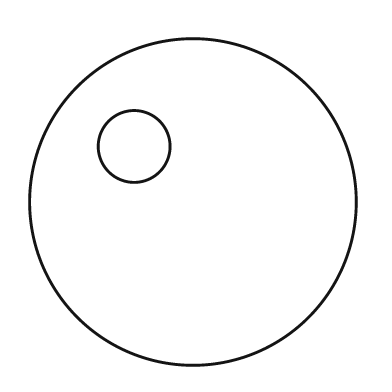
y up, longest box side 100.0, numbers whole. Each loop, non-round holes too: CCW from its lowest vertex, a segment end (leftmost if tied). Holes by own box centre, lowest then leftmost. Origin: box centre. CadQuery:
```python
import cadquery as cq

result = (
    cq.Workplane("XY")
    .moveTo(0.0, 0.0)
    .circle(50.0)
    .moveTo(-18.0, 17.0)
    .circle(11.0)
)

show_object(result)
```